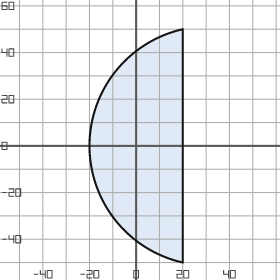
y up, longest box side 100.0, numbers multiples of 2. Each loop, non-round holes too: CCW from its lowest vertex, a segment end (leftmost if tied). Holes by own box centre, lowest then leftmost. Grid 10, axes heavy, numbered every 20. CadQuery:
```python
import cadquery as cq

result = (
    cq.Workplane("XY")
    .moveTo(20.0, -50.0)
    .lineTo(20.0, 50.0)
    .threePointArc((-20.0, 0.0), (20.0, -50.0))
    .close()
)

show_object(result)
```